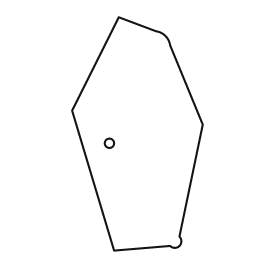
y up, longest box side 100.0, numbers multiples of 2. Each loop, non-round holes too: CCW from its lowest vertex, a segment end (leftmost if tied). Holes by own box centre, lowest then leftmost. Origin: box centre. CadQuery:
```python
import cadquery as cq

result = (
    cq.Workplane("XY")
    .moveTo(-10.0, -50.0)
    .lineTo(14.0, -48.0)
    .threePointArc((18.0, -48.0), (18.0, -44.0))
    .lineTo(28.0, 4.0)
    .lineTo(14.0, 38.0)
    .threePointArc((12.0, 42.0), (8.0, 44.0))
    .lineTo(-8.0, 50.0)
    .lineTo(-28.0, 10.0)
    .close()
    .moveTo(-12.0, -4.0)
    .circle(2.0)
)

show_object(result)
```